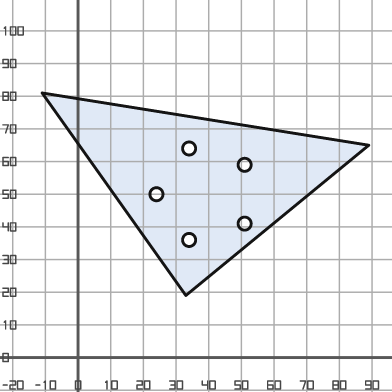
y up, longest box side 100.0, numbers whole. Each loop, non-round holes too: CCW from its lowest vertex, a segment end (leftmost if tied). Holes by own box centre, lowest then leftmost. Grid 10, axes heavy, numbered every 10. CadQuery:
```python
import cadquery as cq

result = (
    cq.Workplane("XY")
    .moveTo(33.0, 19.0)
    .lineTo(89.0, 65.0)
    .lineTo(-11.0, 81.0)
    .close()
    .moveTo(34.0, 36.0)
    .circle(2.0)
    .moveTo(51.0, 41.0)
    .circle(2.0)
    .moveTo(24.0, 50.0)
    .circle(2.0)
    .moveTo(51.0, 59.0)
    .circle(2.0)
    .moveTo(34.0, 64.0)
    .circle(2.0)
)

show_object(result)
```